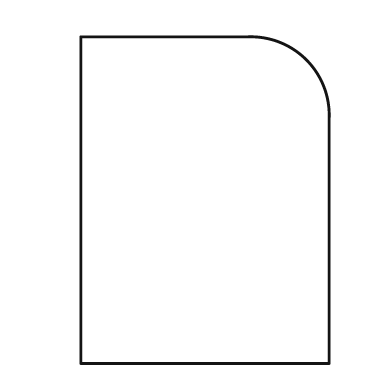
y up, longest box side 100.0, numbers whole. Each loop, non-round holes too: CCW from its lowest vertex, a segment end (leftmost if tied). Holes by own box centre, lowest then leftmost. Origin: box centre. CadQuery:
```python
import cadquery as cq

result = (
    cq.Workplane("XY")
    .moveTo(-38.0, -50.0)
    .lineTo(38.0, -50.0)
    .lineTo(38.0, 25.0)
    .threePointArc((31.0, 43.0), (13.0, 50.0))
    .lineTo(-38.0, 50.0)
    .close()
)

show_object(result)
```